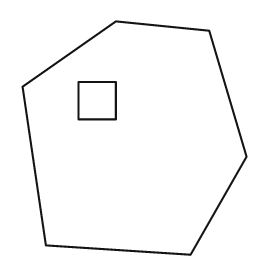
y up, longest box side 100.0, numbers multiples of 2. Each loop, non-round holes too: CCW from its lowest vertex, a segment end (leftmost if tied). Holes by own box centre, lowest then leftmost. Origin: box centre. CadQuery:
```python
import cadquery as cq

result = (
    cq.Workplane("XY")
    .moveTo(24.0, -50.0)
    .lineTo(48.0, -8.0)
    .lineTo(32.0, 46.0)
    .lineTo(-8.0, 50.0)
    .lineTo(-48.0, 22.0)
    .lineTo(-38.0, -46.0)
    .close()
    .moveTo(-24.0, 8.0)
    .lineTo(-8.0, 8.0)
    .lineTo(-8.0, 24.0)
    .lineTo(-24.0, 24.0)
    .close()
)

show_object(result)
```